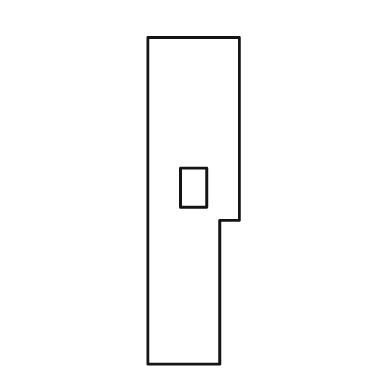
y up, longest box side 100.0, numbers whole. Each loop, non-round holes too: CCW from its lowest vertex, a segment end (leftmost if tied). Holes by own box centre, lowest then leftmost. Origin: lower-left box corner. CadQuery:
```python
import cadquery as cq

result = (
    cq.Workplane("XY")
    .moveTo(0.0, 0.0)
    .lineTo(22.0, 0.0)
    .lineTo(22.0, 44.0)
    .lineTo(28.0, 44.0)
    .lineTo(28.0, 100.0)
    .lineTo(0.0, 100.0)
    .close()
    .moveTo(10.0, 48.0)
    .lineTo(18.0, 48.0)
    .lineTo(18.0, 60.0)
    .lineTo(10.0, 60.0)
    .close()
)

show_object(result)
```